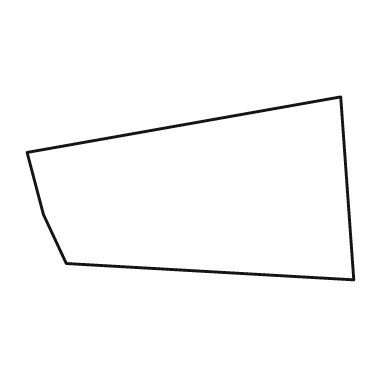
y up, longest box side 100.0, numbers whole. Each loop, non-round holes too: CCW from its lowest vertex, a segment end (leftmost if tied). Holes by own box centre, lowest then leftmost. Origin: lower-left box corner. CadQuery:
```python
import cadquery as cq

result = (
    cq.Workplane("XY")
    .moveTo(100.0, 0.0)
    .lineTo(96.0, 56.0)
    .lineTo(0.0, 39.0)
    .lineTo(5.0, 20.0)
    .lineTo(12.0, 5.0)
    .close()
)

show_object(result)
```